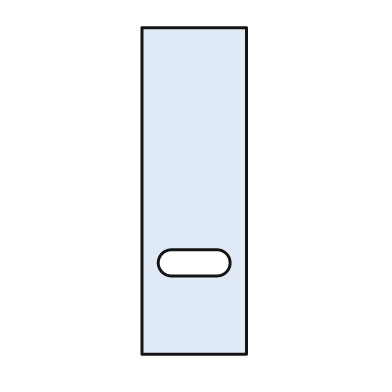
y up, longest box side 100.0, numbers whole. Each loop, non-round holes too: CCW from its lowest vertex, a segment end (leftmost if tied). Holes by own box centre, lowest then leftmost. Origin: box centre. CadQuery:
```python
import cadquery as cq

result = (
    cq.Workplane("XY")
    .moveTo(-16.0, -50.0)
    .lineTo(16.0, -50.0)
    .lineTo(16.0, 50.0)
    .lineTo(-16.0, 50.0)
    .close()
    .moveTo(-7.0, -26.0)
    .lineTo(7.0, -26.0)
    .threePointArc((11.0, -22.0), (7.0, -18.0))
    .lineTo(-7.0, -18.0)
    .threePointArc((-11.0, -22.0), (-7.0, -26.0))
    .close()
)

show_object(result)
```